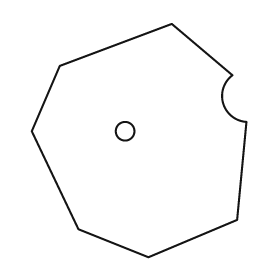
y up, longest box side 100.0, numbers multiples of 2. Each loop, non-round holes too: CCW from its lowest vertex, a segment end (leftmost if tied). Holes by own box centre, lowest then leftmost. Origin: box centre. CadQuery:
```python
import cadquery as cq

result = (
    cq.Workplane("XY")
    .moveTo(4.0, -50.0)
    .lineTo(42.0, -34.0)
    .lineTo(46.0, 8.0)
    .threePointArc((36.0, 16.0), (40.0, 28.0))
    .lineTo(14.0, 50.0)
    .lineTo(-34.0, 32.0)
    .lineTo(-46.0, 4.0)
    .lineTo(-26.0, -38.0)
    .close()
    .moveTo(-6.0, 4.0)
    .circle(4.0)
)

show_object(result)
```